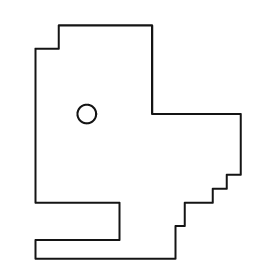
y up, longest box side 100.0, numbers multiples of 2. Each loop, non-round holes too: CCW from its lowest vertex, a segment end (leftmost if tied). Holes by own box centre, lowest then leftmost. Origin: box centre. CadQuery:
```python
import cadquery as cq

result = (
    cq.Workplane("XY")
    .moveTo(-44.0, -50.0)
    .lineTo(16.0, -50.0)
    .lineTo(16.0, -36.0)
    .lineTo(20.0, -36.0)
    .lineTo(20.0, -26.0)
    .lineTo(32.0, -26.0)
    .lineTo(32.0, -20.0)
    .lineTo(38.0, -20.0)
    .lineTo(38.0, -14.0)
    .lineTo(44.0, -14.0)
    .lineTo(44.0, 12.0)
    .lineTo(6.0, 12.0)
    .lineTo(6.0, 50.0)
    .lineTo(-34.0, 50.0)
    .lineTo(-34.0, 40.0)
    .lineTo(-44.0, 40.0)
    .lineTo(-44.0, -26.0)
    .lineTo(-8.0, -26.0)
    .lineTo(-8.0, -42.0)
    .lineTo(-44.0, -42.0)
    .close()
    .moveTo(-22.0, 12.0)
    .circle(4.0)
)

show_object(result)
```